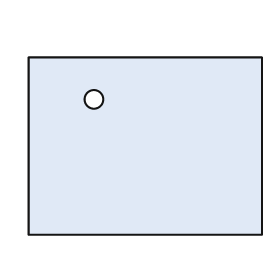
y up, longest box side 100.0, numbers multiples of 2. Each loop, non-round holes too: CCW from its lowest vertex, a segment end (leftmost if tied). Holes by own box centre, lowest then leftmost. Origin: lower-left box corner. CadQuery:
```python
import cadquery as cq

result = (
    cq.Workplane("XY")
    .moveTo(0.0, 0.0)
    .lineTo(100.0, 0.0)
    .lineTo(100.0, 76.0)
    .lineTo(0.0, 76.0)
    .close()
    .moveTo(28.0, 58.0)
    .circle(4.0)
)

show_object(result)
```